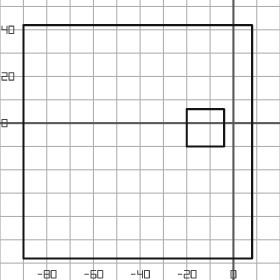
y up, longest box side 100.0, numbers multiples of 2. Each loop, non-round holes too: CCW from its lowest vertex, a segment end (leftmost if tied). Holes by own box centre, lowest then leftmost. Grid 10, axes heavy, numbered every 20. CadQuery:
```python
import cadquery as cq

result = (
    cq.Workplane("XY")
    .moveTo(-90.0, -58.0)
    .lineTo(8.0, -58.0)
    .lineTo(8.0, 42.0)
    .lineTo(-90.0, 42.0)
    .close()
    .moveTo(-20.0, -10.0)
    .lineTo(-4.0, -10.0)
    .lineTo(-4.0, 6.0)
    .lineTo(-20.0, 6.0)
    .close()
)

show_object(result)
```